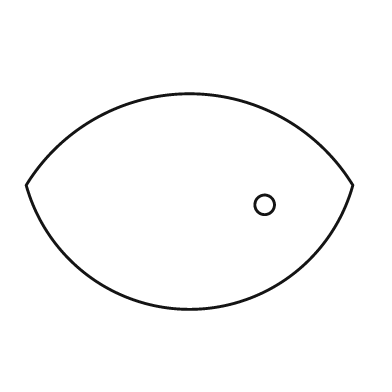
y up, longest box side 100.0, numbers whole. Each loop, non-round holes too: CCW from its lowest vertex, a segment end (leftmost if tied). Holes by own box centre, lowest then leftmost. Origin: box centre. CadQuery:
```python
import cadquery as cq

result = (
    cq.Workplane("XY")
    .moveTo(-50.0, 5.0)
    .threePointArc((0.0, -33.0), (50.0, 5.0))
    .threePointArc((0.0, 33.0), (-50.0, 5.0))
    .close()
    .moveTo(23.0, -1.0)
    .circle(3.0)
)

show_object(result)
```